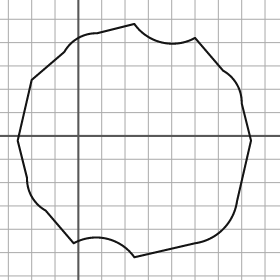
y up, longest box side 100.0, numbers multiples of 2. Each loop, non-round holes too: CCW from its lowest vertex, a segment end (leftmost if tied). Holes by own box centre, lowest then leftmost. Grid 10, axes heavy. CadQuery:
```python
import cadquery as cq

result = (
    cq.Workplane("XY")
    .moveTo(24.0, -52.0)
    .lineTo(50.0, -46.0)
    .threePointArc((62.0, -40.0), (68.0, -28.0))
    .lineTo(74.0, -2.0)
    .lineTo(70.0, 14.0)
    .threePointArc((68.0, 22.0), (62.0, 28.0))
    .lineTo(50.0, 42.0)
    .threePointArc((36.0, 40.0), (24.0, 48.0))
    .lineTo(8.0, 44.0)
    .threePointArc((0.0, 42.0), (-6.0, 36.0))
    .lineTo(-20.0, 24.0)
    .lineTo(-26.0, -2.0)
    .lineTo(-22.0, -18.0)
    .threePointArc((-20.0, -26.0), (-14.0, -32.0))
    .lineTo(-2.0, -46.0)
    .threePointArc((12.0, -44.0), (24.0, -52.0))
    .close()
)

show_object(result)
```